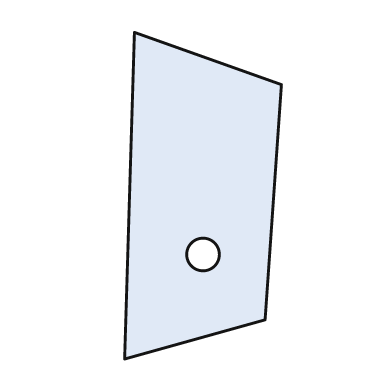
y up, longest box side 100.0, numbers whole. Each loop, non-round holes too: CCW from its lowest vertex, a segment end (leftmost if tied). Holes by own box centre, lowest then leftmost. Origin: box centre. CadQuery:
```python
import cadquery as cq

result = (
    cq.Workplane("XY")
    .moveTo(-24.0, -50.0)
    .lineTo(19.0, -38.0)
    .lineTo(24.0, 34.0)
    .lineTo(-21.0, 50.0)
    .close()
    .moveTo(0.0, -18.0)
    .circle(5.0)
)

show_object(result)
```